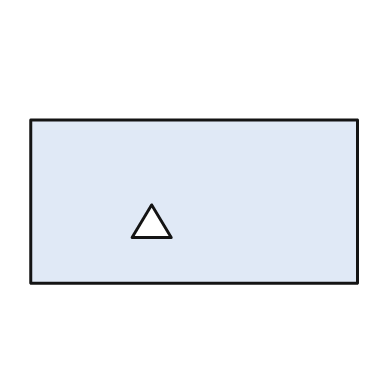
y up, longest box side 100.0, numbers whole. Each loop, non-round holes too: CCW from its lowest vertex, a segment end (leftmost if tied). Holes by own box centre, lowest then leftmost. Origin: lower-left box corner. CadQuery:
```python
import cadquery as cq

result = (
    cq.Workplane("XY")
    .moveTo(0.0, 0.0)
    .lineTo(100.0, 0.0)
    .lineTo(100.0, 50.0)
    .lineTo(0.0, 50.0)
    .close()
    .moveTo(31.0, 14.0)
    .lineTo(43.0, 14.0)
    .lineTo(37.0, 24.0)
    .close()
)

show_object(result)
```